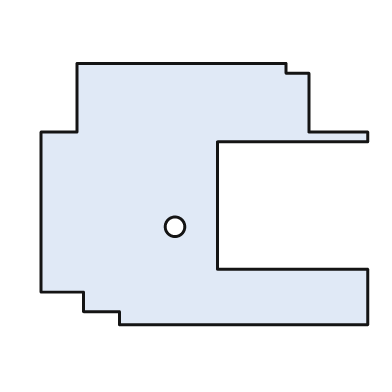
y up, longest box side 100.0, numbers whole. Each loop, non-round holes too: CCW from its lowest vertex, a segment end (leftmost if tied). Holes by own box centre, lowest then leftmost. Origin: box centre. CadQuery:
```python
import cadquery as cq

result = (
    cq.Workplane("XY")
    .moveTo(-26.0, -40.0)
    .lineTo(50.0, -40.0)
    .lineTo(50.0, -23.0)
    .lineTo(4.0, -23.0)
    .lineTo(4.0, 16.0)
    .lineTo(50.0, 16.0)
    .lineTo(50.0, 19.0)
    .lineTo(32.0, 19.0)
    .lineTo(32.0, 37.0)
    .lineTo(25.0, 37.0)
    .lineTo(25.0, 40.0)
    .lineTo(-39.0, 40.0)
    .lineTo(-39.0, 19.0)
    .lineTo(-50.0, 19.0)
    .lineTo(-50.0, -30.0)
    .lineTo(-37.0, -30.0)
    .lineTo(-37.0, -36.0)
    .lineTo(-26.0, -36.0)
    .close()
    .moveTo(-9.0, -10.0)
    .circle(3.0)
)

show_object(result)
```